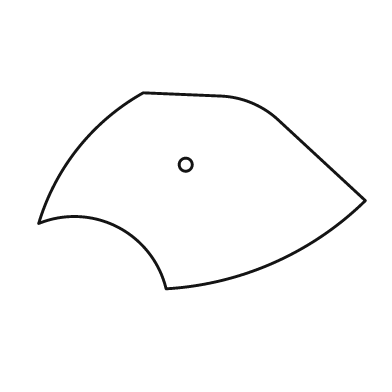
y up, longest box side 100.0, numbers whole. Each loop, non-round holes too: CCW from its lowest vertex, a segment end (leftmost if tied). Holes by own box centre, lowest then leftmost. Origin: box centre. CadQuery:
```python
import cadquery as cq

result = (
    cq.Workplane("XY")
    .moveTo(-11.0, -30.0)
    .threePointArc((22.0, -22.0), (50.0, -3.0))
    .lineTo(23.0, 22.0)
    .threePointArc((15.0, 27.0), (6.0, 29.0))
    .lineTo(-18.0, 30.0)
    .threePointArc((-38.0, 13.0), (-50.0, -10.0))
    .threePointArc((-26.0, -11.0), (-11.0, -30.0))
    .close()
    .moveTo(-5.0, 8.0)
    .circle(2.0)
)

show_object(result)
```